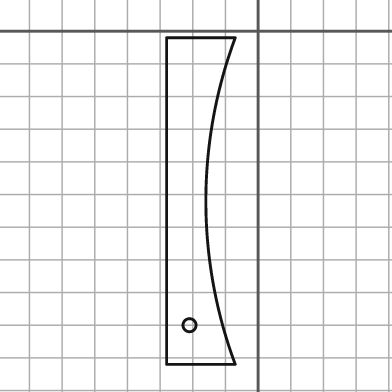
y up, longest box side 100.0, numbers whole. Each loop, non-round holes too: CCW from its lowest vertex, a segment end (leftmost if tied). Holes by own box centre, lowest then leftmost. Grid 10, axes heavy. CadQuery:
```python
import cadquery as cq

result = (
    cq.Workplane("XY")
    .moveTo(-28.0, -102.0)
    .lineTo(-7.0, -102.0)
    .threePointArc((-16.0, -52.0), (-7.0, -2.0))
    .lineTo(-28.0, -2.0)
    .close()
    .moveTo(-21.0, -90.0)
    .circle(2.0)
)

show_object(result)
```